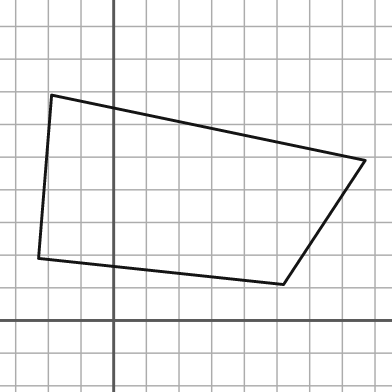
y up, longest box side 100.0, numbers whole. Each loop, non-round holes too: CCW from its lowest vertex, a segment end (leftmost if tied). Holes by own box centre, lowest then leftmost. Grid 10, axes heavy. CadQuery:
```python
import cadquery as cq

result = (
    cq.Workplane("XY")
    .moveTo(52.0, 11.0)
    .lineTo(77.0, 49.0)
    .lineTo(-19.0, 69.0)
    .lineTo(-23.0, 19.0)
    .close()
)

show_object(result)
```